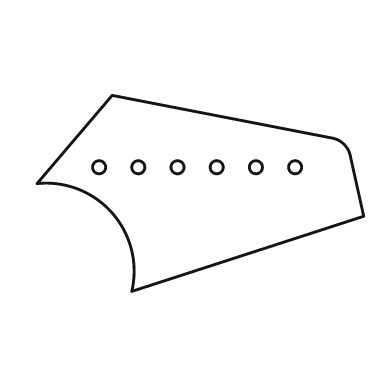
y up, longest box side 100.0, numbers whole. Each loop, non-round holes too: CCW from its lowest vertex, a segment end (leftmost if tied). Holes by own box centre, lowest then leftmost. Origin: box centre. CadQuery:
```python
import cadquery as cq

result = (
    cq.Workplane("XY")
    .moveTo(-21.0, -30.0)
    .lineTo(50.0, -7.0)
    .lineTo(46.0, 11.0)
    .threePointArc((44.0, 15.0), (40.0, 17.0))
    .lineTo(-27.0, 30.0)
    .lineTo(-50.0, 3.0)
    .threePointArc((-27.0, -6.0), (-21.0, -30.0))
    .close()
    .moveTo(-31.0, 8.0)
    .circle(2.0)
    .moveTo(-19.0, 8.0)
    .circle(2.0)
    .moveTo(-7.0, 8.0)
    .circle(2.0)
    .moveTo(5.0, 8.0)
    .circle(2.0)
    .moveTo(17.0, 8.0)
    .circle(2.0)
    .moveTo(29.0, 8.0)
    .circle(2.0)
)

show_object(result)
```